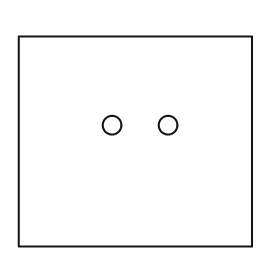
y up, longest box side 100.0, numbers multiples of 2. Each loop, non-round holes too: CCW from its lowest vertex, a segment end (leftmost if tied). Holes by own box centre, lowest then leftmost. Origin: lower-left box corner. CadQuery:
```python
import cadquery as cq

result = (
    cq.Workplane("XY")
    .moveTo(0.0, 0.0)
    .lineTo(100.0, 0.0)
    .lineTo(100.0, 90.0)
    .lineTo(0.0, 90.0)
    .close()
    .moveTo(40.0, 52.0)
    .circle(4.0)
    .moveTo(64.0, 52.0)
    .circle(4.0)
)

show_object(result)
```